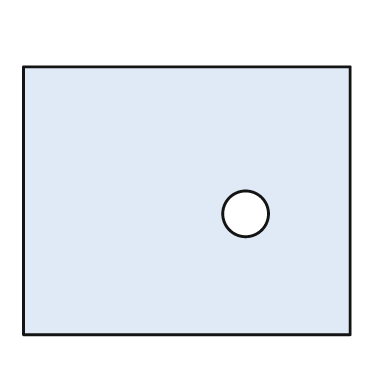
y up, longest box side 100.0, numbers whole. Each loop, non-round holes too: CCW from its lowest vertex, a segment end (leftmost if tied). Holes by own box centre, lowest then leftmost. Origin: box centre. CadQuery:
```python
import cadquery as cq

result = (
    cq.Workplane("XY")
    .moveTo(-50.0, -41.0)
    .lineTo(50.0, -41.0)
    .lineTo(50.0, 41.0)
    .lineTo(-50.0, 41.0)
    .close()
    .moveTo(18.0, -4.0)
    .circle(7.0)
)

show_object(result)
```